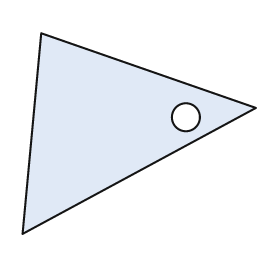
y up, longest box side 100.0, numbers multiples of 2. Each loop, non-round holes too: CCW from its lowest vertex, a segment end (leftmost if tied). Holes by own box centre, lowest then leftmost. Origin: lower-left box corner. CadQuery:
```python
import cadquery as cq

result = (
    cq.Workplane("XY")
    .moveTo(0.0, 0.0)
    .lineTo(100.0, 54.0)
    .lineTo(8.0, 86.0)
    .close()
    .moveTo(70.0, 50.0)
    .circle(6.0)
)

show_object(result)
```